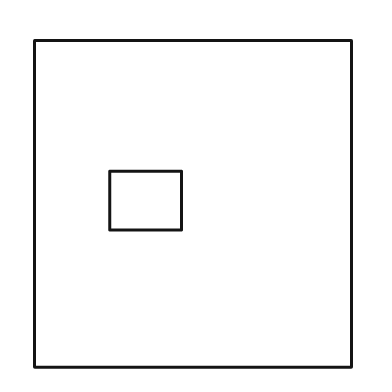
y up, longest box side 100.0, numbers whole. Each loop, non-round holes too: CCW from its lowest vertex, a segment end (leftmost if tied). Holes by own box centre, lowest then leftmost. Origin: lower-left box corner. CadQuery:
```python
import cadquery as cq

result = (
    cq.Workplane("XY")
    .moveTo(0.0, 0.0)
    .lineTo(97.0, 0.0)
    .lineTo(97.0, 100.0)
    .lineTo(0.0, 100.0)
    .close()
    .moveTo(23.0, 42.0)
    .lineTo(45.0, 42.0)
    .lineTo(45.0, 60.0)
    .lineTo(23.0, 60.0)
    .close()
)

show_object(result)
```